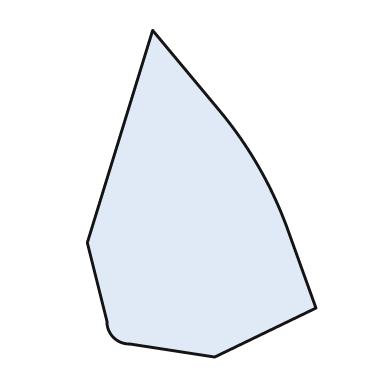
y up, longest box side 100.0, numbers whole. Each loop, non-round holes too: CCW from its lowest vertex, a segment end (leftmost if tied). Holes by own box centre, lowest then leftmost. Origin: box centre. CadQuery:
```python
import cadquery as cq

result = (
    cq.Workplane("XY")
    .moveTo(4.0, -50.0)
    .lineTo(35.0, -35.0)
    .lineTo(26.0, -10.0)
    .threePointArc((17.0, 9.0), (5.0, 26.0))
    .lineTo(-15.0, 50.0)
    .lineTo(-35.0, -15.0)
    .lineTo(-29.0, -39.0)
    .threePointArc((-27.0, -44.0), (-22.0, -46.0))
    .close()
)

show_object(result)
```